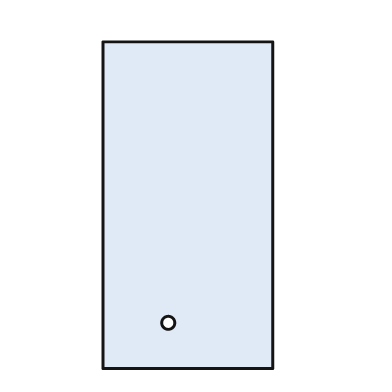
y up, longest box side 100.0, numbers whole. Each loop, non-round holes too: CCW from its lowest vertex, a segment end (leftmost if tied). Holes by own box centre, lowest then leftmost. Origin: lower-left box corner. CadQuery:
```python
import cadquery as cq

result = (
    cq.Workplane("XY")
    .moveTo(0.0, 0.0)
    .lineTo(52.0, 0.0)
    .lineTo(52.0, 100.0)
    .lineTo(0.0, 100.0)
    .close()
    .moveTo(20.0, 14.0)
    .circle(2.0)
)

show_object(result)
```